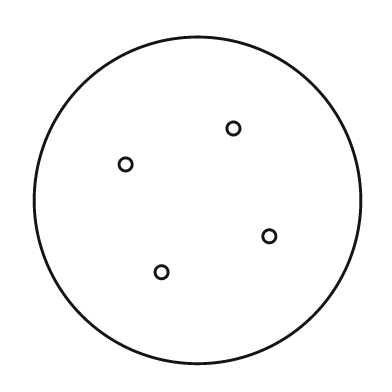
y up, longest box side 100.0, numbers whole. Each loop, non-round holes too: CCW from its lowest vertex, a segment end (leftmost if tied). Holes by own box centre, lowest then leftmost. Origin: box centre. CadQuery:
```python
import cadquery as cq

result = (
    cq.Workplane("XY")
    .moveTo(0.0, 0.0)
    .circle(50.0)
    .moveTo(-11.0, -22.0)
    .circle(2.0)
    .moveTo(22.0, -11.0)
    .circle(2.0)
    .moveTo(-22.0, 11.0)
    .circle(2.0)
    .moveTo(11.0, 22.0)
    .circle(2.0)
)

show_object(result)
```